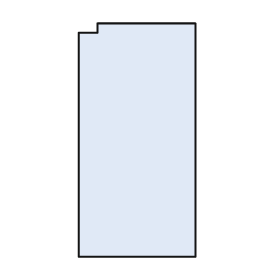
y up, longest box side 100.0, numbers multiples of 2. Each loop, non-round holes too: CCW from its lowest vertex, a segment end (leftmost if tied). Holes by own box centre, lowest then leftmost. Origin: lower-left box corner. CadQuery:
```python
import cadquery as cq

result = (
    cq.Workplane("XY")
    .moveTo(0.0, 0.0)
    .lineTo(50.0, 0.0)
    .lineTo(50.0, 100.0)
    .lineTo(8.0, 100.0)
    .lineTo(8.0, 96.0)
    .lineTo(0.0, 96.0)
    .close()
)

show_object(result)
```